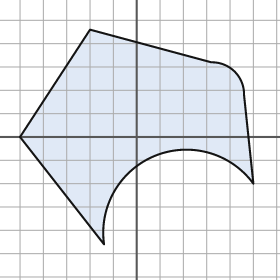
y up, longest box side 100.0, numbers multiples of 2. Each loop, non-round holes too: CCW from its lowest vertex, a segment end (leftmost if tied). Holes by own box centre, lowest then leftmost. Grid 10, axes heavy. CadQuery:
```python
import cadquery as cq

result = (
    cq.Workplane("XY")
    .moveTo(-14.0, -46.0)
    .threePointArc((8.0, -8.0), (50.0, -20.0))
    .lineTo(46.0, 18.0)
    .threePointArc((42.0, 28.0), (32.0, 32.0))
    .lineTo(-20.0, 46.0)
    .lineTo(-50.0, 0.0)
    .close()
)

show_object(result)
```